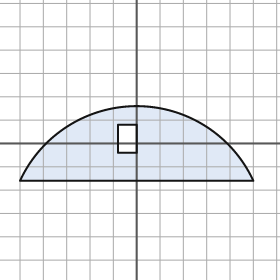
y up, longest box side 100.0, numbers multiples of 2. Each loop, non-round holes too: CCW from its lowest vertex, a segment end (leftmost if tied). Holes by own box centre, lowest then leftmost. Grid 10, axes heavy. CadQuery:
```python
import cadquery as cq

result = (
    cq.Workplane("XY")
    .moveTo(-50.0, -16.0)
    .lineTo(50.0, -16.0)
    .threePointArc((0.0, 16.0), (-50.0, -16.0))
    .close()
    .moveTo(-8.0, -4.0)
    .lineTo(0.0, -4.0)
    .lineTo(0.0, 8.0)
    .lineTo(-8.0, 8.0)
    .close()
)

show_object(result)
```